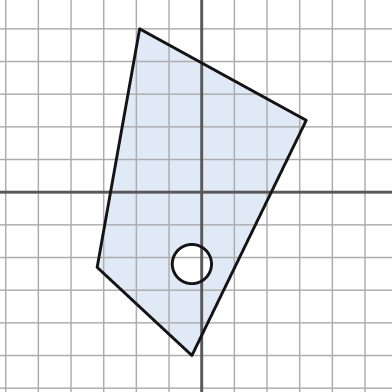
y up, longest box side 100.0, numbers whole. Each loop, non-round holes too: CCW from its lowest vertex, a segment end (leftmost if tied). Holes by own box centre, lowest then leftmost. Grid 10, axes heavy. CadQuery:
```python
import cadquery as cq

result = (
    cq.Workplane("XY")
    .moveTo(-3.0, -50.0)
    .lineTo(32.0, 22.0)
    .lineTo(-19.0, 50.0)
    .lineTo(-32.0, -23.0)
    .close()
    .moveTo(-3.0, -22.0)
    .circle(6.0)
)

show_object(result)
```